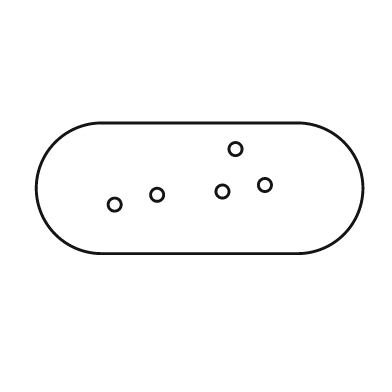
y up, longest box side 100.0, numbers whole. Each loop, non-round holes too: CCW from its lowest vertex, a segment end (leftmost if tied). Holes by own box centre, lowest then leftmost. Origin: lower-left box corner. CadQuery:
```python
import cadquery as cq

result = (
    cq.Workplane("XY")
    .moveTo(20.0, 0.0)
    .lineTo(80.0, 0.0)
    .threePointArc((100.0, 20.0), (80.0, 40.0))
    .lineTo(20.0, 40.0)
    .threePointArc((0.0, 20.0), (20.0, 0.0))
    .close()
    .moveTo(24.0, 15.0)
    .circle(2.0)
    .moveTo(37.0, 18.0)
    .circle(2.0)
    .moveTo(57.0, 19.0)
    .circle(2.0)
    .moveTo(70.0, 21.0)
    .circle(2.0)
    .moveTo(61.0, 32.0)
    .circle(2.0)
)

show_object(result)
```